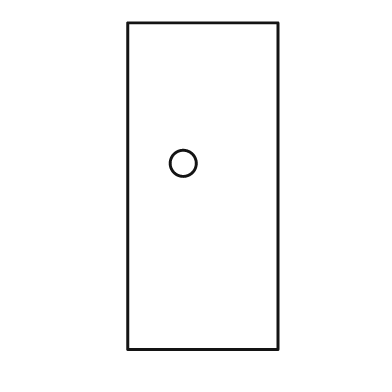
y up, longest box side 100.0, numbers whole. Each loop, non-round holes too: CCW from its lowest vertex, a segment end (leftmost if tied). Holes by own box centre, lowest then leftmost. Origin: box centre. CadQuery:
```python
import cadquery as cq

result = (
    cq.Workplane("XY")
    .moveTo(-23.0, -50.0)
    .lineTo(23.0, -50.0)
    .lineTo(23.0, 50.0)
    .lineTo(-23.0, 50.0)
    .close()
    .moveTo(-6.0, 7.0)
    .circle(4.0)
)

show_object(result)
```